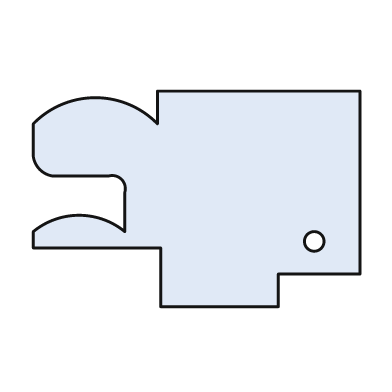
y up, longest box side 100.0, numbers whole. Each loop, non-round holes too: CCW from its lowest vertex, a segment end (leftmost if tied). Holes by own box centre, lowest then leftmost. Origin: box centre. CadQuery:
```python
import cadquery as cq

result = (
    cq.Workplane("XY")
    .moveTo(-11.0, -33.0)
    .lineTo(25.0, -33.0)
    .lineTo(25.0, -23.0)
    .lineTo(50.0, -23.0)
    .lineTo(50.0, 33.0)
    .lineTo(-12.0, 33.0)
    .lineTo(-12.0, 23.0)
    .threePointArc((-31.0, 31.0), (-50.0, 23.0))
    .lineTo(-50.0, 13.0)
    .threePointArc((-48.0, 9.0), (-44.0, 7.0))
    .lineTo(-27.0, 7.0)
    .threePointArc((-23.0, 6.0), (-22.0, 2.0))
    .lineTo(-22.0, -10.0)
    .threePointArc((-36.0, -5.0), (-50.0, -10.0))
    .lineTo(-50.0, -15.0)
    .lineTo(-11.0, -15.0)
    .close()
    .moveTo(36.0, -13.0)
    .circle(3.0)
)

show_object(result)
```